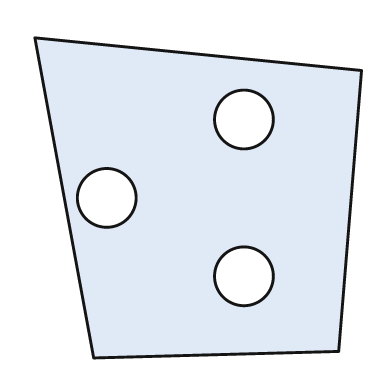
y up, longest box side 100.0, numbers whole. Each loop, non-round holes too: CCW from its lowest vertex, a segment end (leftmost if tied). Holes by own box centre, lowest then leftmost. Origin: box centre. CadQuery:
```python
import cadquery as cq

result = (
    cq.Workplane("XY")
    .moveTo(-32.0, -49.0)
    .lineTo(43.0, -47.0)
    .lineTo(50.0, 39.0)
    .lineTo(-50.0, 49.0)
    .close()
    .moveTo(14.0, -24.0)
    .circle(9.0)
    .moveTo(-28.0, 0.0)
    .circle(9.0)
    .moveTo(14.0, 24.0)
    .circle(9.0)
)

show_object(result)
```